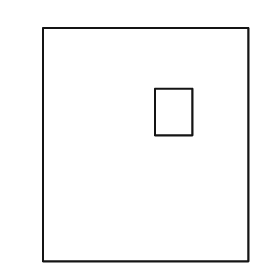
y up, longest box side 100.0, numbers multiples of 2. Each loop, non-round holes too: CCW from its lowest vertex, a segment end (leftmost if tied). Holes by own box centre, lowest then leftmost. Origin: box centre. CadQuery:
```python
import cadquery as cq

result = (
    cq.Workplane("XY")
    .moveTo(-44.0, -50.0)
    .lineTo(44.0, -50.0)
    .lineTo(44.0, 50.0)
    .lineTo(-44.0, 50.0)
    .close()
    .moveTo(4.0, 4.0)
    .lineTo(20.0, 4.0)
    .lineTo(20.0, 24.0)
    .lineTo(4.0, 24.0)
    .close()
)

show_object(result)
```